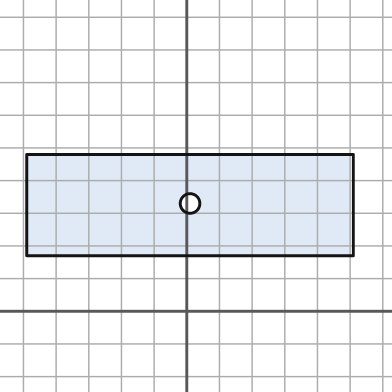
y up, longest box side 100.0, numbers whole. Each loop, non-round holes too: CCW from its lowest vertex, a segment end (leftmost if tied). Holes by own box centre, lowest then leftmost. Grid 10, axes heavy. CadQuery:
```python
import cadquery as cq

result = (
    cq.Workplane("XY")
    .moveTo(-49.0, 17.0)
    .lineTo(51.0, 17.0)
    .lineTo(51.0, 48.0)
    .lineTo(-49.0, 48.0)
    .close()
    .moveTo(1.0, 33.0)
    .circle(3.0)
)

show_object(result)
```